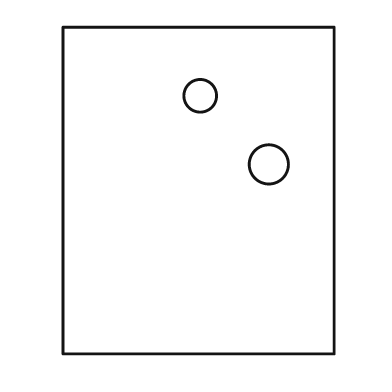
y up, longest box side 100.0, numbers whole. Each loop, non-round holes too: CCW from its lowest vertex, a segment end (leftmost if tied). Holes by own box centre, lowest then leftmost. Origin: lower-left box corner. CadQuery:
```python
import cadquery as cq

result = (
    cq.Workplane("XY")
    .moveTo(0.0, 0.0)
    .lineTo(83.0, 0.0)
    .lineTo(83.0, 100.0)
    .lineTo(0.0, 100.0)
    .close()
    .moveTo(63.0, 58.0)
    .circle(6.0)
    .moveTo(42.0, 79.0)
    .circle(5.0)
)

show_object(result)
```